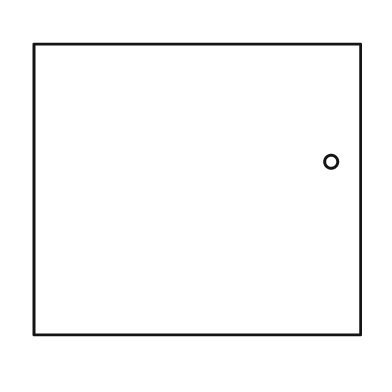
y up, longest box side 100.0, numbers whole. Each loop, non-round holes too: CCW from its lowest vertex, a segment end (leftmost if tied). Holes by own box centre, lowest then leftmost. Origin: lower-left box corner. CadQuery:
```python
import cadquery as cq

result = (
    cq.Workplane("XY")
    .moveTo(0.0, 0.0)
    .lineTo(100.0, 0.0)
    .lineTo(100.0, 89.0)
    .lineTo(0.0, 89.0)
    .close()
    .moveTo(91.0, 53.0)
    .circle(2.0)
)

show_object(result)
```